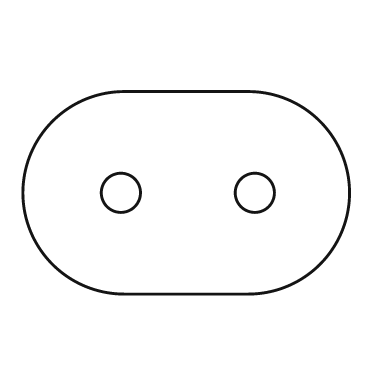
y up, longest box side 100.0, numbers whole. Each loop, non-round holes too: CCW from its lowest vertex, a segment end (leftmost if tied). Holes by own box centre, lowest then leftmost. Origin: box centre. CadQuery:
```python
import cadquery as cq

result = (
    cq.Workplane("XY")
    .moveTo(-19.0, -31.0)
    .lineTo(19.0, -31.0)
    .threePointArc((50.0, 0.0), (19.0, 31.0))
    .lineTo(-19.0, 31.0)
    .threePointArc((-50.0, 0.0), (-19.0, -31.0))
    .close()
    .moveTo(-20.0, 0.0)
    .circle(6.0)
    .moveTo(21.0, 0.0)
    .circle(6.0)
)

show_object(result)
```